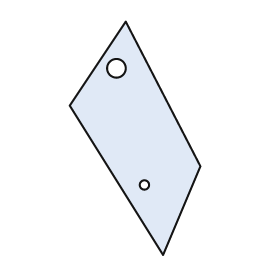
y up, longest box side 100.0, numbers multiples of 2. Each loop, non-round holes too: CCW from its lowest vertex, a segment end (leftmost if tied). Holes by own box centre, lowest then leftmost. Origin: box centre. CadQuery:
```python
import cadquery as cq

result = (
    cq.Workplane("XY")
    .moveTo(12.0, -50.0)
    .lineTo(28.0, -12.0)
    .lineTo(-4.0, 50.0)
    .lineTo(-28.0, 14.0)
    .close()
    .moveTo(4.0, -20.0)
    .circle(2.0)
    .moveTo(-8.0, 30.0)
    .circle(4.0)
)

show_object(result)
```